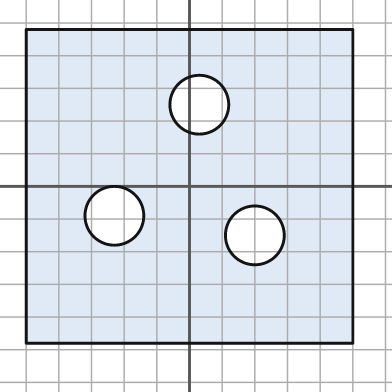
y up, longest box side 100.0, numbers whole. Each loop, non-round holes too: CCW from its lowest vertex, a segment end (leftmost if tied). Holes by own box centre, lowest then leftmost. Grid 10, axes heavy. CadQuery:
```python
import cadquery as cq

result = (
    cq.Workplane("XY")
    .moveTo(-50.0, -48.0)
    .lineTo(50.0, -48.0)
    .lineTo(50.0, 48.0)
    .lineTo(-50.0, 48.0)
    .close()
    .moveTo(20.0, -15.0)
    .circle(9.0)
    .moveTo(-23.0, -9.0)
    .circle(9.0)
    .moveTo(3.0, 25.0)
    .circle(9.0)
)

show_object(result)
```